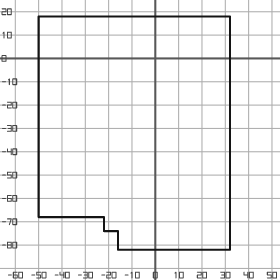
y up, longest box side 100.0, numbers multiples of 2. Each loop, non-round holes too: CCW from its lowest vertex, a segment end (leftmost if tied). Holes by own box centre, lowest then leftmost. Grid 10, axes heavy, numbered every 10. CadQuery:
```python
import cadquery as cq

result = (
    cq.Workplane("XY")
    .moveTo(-16.0, -82.0)
    .lineTo(32.0, -82.0)
    .lineTo(32.0, 18.0)
    .lineTo(-50.0, 18.0)
    .lineTo(-50.0, -68.0)
    .lineTo(-22.0, -68.0)
    .lineTo(-22.0, -74.0)
    .lineTo(-16.0, -74.0)
    .close()
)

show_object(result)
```